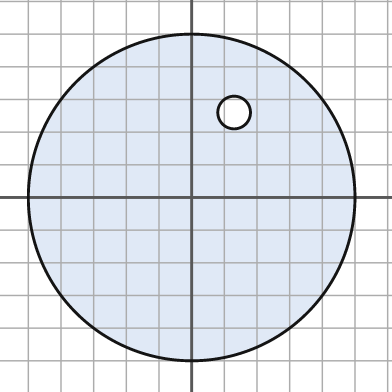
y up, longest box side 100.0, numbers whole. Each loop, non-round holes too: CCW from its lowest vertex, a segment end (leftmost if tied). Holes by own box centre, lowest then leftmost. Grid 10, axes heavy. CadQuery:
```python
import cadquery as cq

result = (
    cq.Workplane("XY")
    .moveTo(0.0, 0.0)
    .circle(50.0)
    .moveTo(13.0, 26.0)
    .circle(5.0)
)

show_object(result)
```